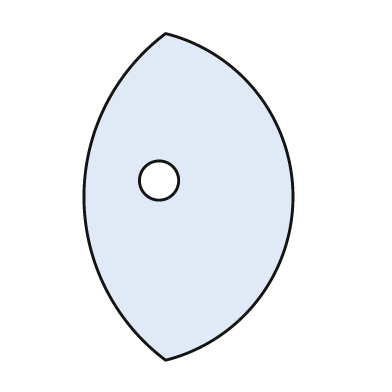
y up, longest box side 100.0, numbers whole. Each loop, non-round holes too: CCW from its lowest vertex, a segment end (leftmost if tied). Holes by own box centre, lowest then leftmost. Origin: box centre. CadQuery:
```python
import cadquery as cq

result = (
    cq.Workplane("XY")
    .moveTo(-7.0, -50.0)
    .threePointArc((32.0, 0.0), (-7.0, 50.0))
    .threePointArc((-32.0, 0.0), (-7.0, -50.0))
    .close()
    .moveTo(-9.0, 5.0)
    .circle(6.0)
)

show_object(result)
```